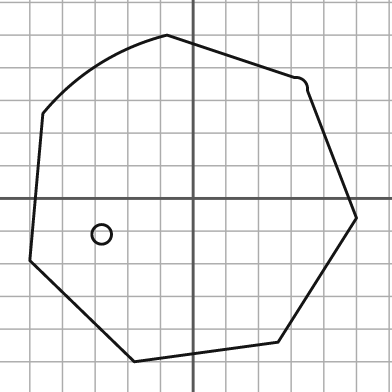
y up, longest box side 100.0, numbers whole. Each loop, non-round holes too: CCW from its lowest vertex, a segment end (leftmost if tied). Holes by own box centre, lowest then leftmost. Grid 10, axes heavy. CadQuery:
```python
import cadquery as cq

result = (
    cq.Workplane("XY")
    .moveTo(-18.0, -50.0)
    .lineTo(26.0, -44.0)
    .lineTo(50.0, -6.0)
    .lineTo(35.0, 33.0)
    .threePointArc((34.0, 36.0), (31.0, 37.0))
    .lineTo(-8.0, 50.0)
    .threePointArc((-29.0, 41.0), (-46.0, 26.0))
    .lineTo(-50.0, -19.0)
    .close()
    .moveTo(-28.0, -11.0)
    .circle(3.0)
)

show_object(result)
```